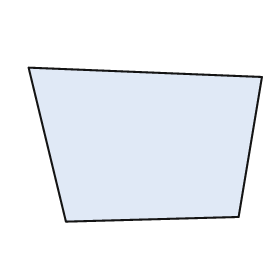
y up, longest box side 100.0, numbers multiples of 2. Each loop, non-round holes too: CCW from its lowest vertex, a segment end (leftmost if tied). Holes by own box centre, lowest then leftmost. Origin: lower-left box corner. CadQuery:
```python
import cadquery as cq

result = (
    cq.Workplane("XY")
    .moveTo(16.0, 0.0)
    .lineTo(90.0, 2.0)
    .lineTo(100.0, 62.0)
    .lineTo(0.0, 66.0)
    .close()
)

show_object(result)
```